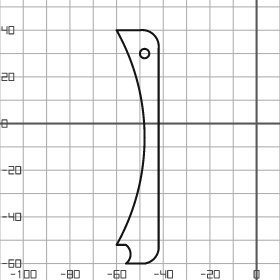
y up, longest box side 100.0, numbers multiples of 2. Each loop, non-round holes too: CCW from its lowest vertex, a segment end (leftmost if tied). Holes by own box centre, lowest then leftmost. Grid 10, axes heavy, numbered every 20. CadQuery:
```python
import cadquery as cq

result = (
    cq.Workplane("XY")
    .moveTo(-56.0, -60.0)
    .lineTo(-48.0, -60.0)
    .threePointArc((-44.0, -58.0), (-42.0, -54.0))
    .lineTo(-42.0, 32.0)
    .threePointArc((-44.0, 38.0), (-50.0, 40.0))
    .lineTo(-60.0, 40.0)
    .threePointArc((-48.0, -6.0), (-60.0, -52.0))
    .lineTo(-56.0, -52.0)
    .threePointArc((-54.0, -56.0), (-56.0, -60.0))
    .close()
    .moveTo(-48.0, 30.0)
    .circle(2.0)
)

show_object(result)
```